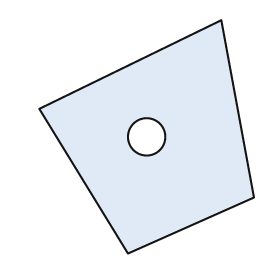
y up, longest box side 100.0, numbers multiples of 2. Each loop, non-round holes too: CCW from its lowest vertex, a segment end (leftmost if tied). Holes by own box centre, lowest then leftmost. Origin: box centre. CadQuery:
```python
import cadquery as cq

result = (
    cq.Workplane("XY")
    .moveTo(-8.0, -50.0)
    .lineTo(46.0, -26.0)
    .lineTo(32.0, 50.0)
    .lineTo(-46.0, 12.0)
    .close()
    .moveTo(0.0, 0.0)
    .circle(8.0)
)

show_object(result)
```